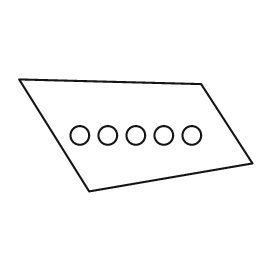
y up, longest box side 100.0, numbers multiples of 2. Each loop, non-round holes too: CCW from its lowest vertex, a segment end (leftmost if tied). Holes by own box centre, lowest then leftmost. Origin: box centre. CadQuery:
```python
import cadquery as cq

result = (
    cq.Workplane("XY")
    .moveTo(-20.0, -24.0)
    .lineTo(50.0, -12.0)
    .lineTo(28.0, 22.0)
    .lineTo(-50.0, 24.0)
    .close()
    .moveTo(-24.0, 0.0)
    .circle(4.0)
    .moveTo(-12.0, 0.0)
    .circle(4.0)
    .moveTo(0.0, 0.0)
    .circle(4.0)
    .moveTo(12.0, 0.0)
    .circle(4.0)
    .moveTo(24.0, 0.0)
    .circle(4.0)
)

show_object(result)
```